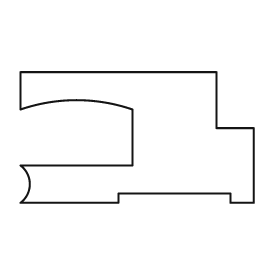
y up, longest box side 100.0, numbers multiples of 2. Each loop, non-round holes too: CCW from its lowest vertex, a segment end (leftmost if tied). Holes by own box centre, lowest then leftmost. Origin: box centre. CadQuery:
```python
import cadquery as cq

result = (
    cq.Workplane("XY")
    .moveTo(-50.0, -28.0)
    .lineTo(-8.0, -28.0)
    .lineTo(-8.0, -24.0)
    .lineTo(40.0, -24.0)
    .lineTo(40.0, -28.0)
    .lineTo(50.0, -28.0)
    .lineTo(50.0, 4.0)
    .lineTo(34.0, 4.0)
    .lineTo(34.0, 28.0)
    .lineTo(-50.0, 28.0)
    .lineTo(-50.0, 12.0)
    .threePointArc((-26.0, 16.0), (-2.0, 12.0))
    .lineTo(-2.0, -12.0)
    .lineTo(-50.0, -12.0)
    .threePointArc((-46.0, -20.0), (-50.0, -28.0))
    .close()
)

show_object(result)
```